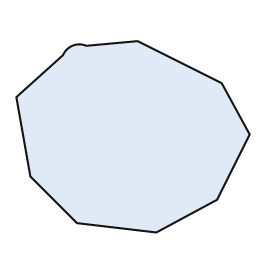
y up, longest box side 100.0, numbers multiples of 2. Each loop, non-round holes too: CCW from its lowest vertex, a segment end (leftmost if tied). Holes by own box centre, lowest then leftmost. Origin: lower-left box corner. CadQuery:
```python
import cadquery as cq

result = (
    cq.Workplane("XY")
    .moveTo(60.0, 0.0)
    .lineTo(86.0, 14.0)
    .lineTo(100.0, 42.0)
    .lineTo(88.0, 64.0)
    .lineTo(52.0, 82.0)
    .lineTo(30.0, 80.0)
    .threePointArc((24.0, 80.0), (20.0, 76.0))
    .lineTo(0.0, 58.0)
    .lineTo(6.0, 24.0)
    .lineTo(26.0, 4.0)
    .close()
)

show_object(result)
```